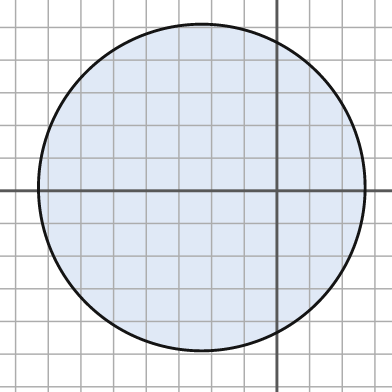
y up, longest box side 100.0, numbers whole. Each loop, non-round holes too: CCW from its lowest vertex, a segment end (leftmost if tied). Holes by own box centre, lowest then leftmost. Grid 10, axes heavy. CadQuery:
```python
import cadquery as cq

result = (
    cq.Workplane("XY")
    .moveTo(-23.0, 1.0)
    .circle(50.0)
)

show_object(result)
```